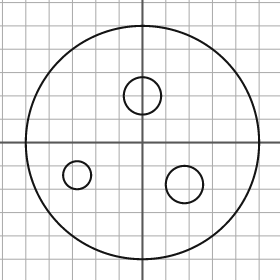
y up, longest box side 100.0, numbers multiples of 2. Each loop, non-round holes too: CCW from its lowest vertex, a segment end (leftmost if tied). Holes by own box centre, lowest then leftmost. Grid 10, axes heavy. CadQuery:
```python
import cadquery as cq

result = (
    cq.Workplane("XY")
    .moveTo(0.0, 0.0)
    .circle(50.0)
    .moveTo(18.0, -18.0)
    .circle(8.0)
    .moveTo(-28.0, -14.0)
    .circle(6.0)
    .moveTo(0.0, 20.0)
    .circle(8.0)
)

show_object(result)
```